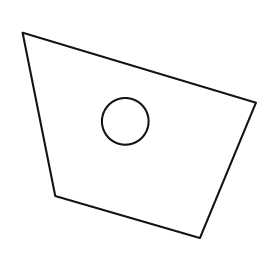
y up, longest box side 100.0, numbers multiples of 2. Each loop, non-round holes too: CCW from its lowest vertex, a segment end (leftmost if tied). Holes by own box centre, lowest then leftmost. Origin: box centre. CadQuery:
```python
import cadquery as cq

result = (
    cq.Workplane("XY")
    .moveTo(26.0, -44.0)
    .lineTo(50.0, 14.0)
    .lineTo(-50.0, 44.0)
    .lineTo(-36.0, -26.0)
    .close()
    .moveTo(-6.0, 6.0)
    .circle(10.0)
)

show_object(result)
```